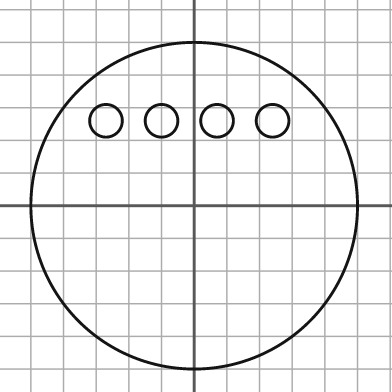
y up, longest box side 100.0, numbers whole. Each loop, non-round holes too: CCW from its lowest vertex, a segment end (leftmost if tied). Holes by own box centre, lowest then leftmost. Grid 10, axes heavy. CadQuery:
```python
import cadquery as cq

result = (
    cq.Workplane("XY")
    .moveTo(0.0, 0.0)
    .circle(50.0)
    .moveTo(-27.0, 26.0)
    .circle(5.0)
    .moveTo(-10.0, 26.0)
    .circle(5.0)
    .moveTo(7.0, 26.0)
    .circle(5.0)
    .moveTo(24.0, 26.0)
    .circle(5.0)
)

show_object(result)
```